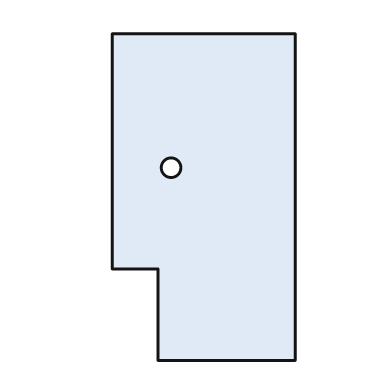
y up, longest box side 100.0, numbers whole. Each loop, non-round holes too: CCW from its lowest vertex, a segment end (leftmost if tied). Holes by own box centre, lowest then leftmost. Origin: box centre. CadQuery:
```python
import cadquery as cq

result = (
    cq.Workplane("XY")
    .moveTo(-14.0, -50.0)
    .lineTo(28.0, -50.0)
    .lineTo(28.0, 50.0)
    .lineTo(-28.0, 50.0)
    .lineTo(-28.0, -22.0)
    .lineTo(-14.0, -22.0)
    .close()
    .moveTo(-10.0, 9.0)
    .circle(3.0)
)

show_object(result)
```